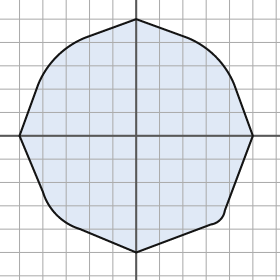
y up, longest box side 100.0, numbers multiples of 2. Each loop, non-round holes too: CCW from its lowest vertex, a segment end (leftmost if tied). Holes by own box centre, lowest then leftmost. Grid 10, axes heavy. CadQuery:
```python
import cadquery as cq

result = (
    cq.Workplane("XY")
    .moveTo(0.0, -50.0)
    .lineTo(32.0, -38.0)
    .threePointArc((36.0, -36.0), (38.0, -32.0))
    .lineTo(50.0, 0.0)
    .lineTo(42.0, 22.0)
    .threePointArc((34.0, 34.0), (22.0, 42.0))
    .lineTo(0.0, 50.0)
    .lineTo(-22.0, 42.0)
    .threePointArc((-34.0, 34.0), (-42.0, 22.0))
    .lineTo(-50.0, 0.0)
    .lineTo(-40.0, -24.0)
    .threePointArc((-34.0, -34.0), (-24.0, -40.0))
    .close()
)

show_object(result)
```